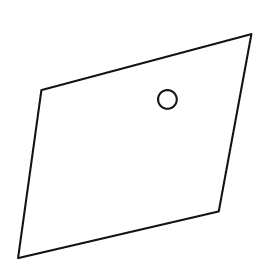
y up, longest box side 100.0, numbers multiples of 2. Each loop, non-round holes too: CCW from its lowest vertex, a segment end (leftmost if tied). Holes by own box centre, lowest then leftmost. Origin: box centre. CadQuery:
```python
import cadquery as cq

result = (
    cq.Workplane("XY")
    .moveTo(-50.0, -48.0)
    .lineTo(36.0, -28.0)
    .lineTo(50.0, 48.0)
    .lineTo(-40.0, 24.0)
    .close()
    .moveTo(14.0, 20.0)
    .circle(4.0)
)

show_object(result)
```